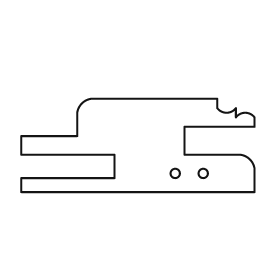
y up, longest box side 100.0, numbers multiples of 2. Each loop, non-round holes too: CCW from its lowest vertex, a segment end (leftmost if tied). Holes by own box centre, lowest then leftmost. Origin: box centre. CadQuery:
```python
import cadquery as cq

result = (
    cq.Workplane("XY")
    .moveTo(-50.0, -20.0)
    .lineTo(50.0, -20.0)
    .lineTo(50.0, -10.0)
    .threePointArc((48.0, -6.0), (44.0, -4.0))
    .lineTo(20.0, -4.0)
    .lineTo(20.0, 8.0)
    .lineTo(50.0, 8.0)
    .lineTo(50.0, 12.0)
    .threePointArc((46.0, 14.0), (42.0, 12.0))
    .lineTo(42.0, 16.0)
    .threePointArc((38.0, 14.0), (34.0, 16.0))
    .lineTo(34.0, 20.0)
    .lineTo(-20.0, 20.0)
    .threePointArc((-24.0, 18.0), (-26.0, 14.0))
    .lineTo(-26.0, 4.0)
    .lineTo(-50.0, 4.0)
    .lineTo(-50.0, -4.0)
    .lineTo(-10.0, -4.0)
    .lineTo(-10.0, -14.0)
    .lineTo(-50.0, -14.0)
    .close()
    .moveTo(16.0, -12.0)
    .circle(2.0)
    .moveTo(28.0, -12.0)
    .circle(2.0)
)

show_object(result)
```